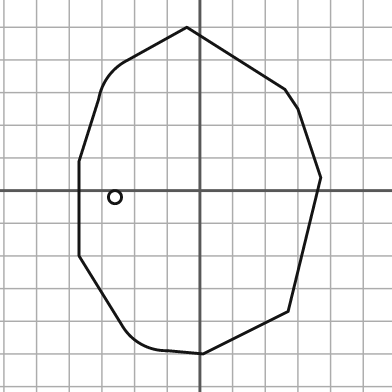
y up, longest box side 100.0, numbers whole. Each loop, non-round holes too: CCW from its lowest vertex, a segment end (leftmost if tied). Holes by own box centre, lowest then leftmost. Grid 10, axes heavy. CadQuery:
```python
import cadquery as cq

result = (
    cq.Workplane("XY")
    .moveTo(1.0, -50.0)
    .lineTo(27.0, -37.0)
    .lineTo(37.0, 4.0)
    .lineTo(30.0, 25.0)
    .lineTo(26.0, 31.0)
    .lineTo(-4.0, 50.0)
    .lineTo(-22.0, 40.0)
    .threePointArc((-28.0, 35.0), (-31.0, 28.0))
    .lineTo(-37.0, 9.0)
    .lineTo(-37.0, -20.0)
    .lineTo(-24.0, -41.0)
    .threePointArc((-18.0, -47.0), (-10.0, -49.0))
    .close()
    .moveTo(-26.0, -2.0)
    .circle(2.0)
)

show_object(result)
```